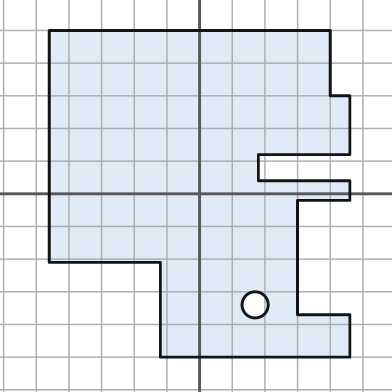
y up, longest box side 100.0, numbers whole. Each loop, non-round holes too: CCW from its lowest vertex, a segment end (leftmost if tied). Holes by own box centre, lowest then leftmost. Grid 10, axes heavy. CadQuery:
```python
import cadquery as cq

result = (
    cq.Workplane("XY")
    .moveTo(-12.0, -50.0)
    .lineTo(46.0, -50.0)
    .lineTo(46.0, -37.0)
    .lineTo(30.0, -37.0)
    .lineTo(30.0, -2.0)
    .lineTo(46.0, -2.0)
    .lineTo(46.0, 4.0)
    .lineTo(18.0, 4.0)
    .lineTo(18.0, 12.0)
    .lineTo(46.0, 12.0)
    .lineTo(46.0, 30.0)
    .lineTo(40.0, 30.0)
    .lineTo(40.0, 50.0)
    .lineTo(-46.0, 50.0)
    .lineTo(-46.0, -21.0)
    .lineTo(-12.0, -21.0)
    .close()
    .moveTo(17.0, -34.0)
    .circle(4.0)
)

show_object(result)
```